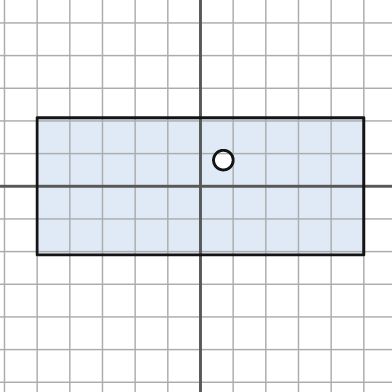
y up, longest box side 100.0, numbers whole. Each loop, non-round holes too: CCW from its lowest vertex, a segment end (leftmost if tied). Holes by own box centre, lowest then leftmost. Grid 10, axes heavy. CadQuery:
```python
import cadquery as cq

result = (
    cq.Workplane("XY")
    .moveTo(-50.0, -21.0)
    .lineTo(50.0, -21.0)
    .lineTo(50.0, 21.0)
    .lineTo(-50.0, 21.0)
    .close()
    .moveTo(7.0, 8.0)
    .circle(3.0)
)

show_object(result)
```